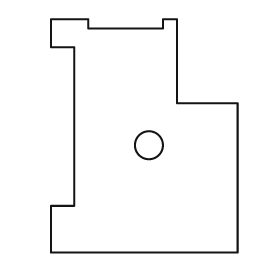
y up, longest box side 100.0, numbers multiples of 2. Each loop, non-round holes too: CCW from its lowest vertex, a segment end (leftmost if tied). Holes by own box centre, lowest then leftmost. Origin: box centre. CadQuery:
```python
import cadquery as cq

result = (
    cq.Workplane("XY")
    .moveTo(-40.0, -50.0)
    .lineTo(40.0, -50.0)
    .lineTo(40.0, 14.0)
    .lineTo(14.0, 14.0)
    .lineTo(14.0, 50.0)
    .lineTo(8.0, 50.0)
    .lineTo(8.0, 46.0)
    .lineTo(-24.0, 46.0)
    .lineTo(-24.0, 50.0)
    .lineTo(-40.0, 50.0)
    .lineTo(-40.0, 38.0)
    .lineTo(-30.0, 38.0)
    .lineTo(-30.0, -30.0)
    .lineTo(-40.0, -30.0)
    .close()
    .moveTo(2.0, -4.0)
    .circle(6.0)
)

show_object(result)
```